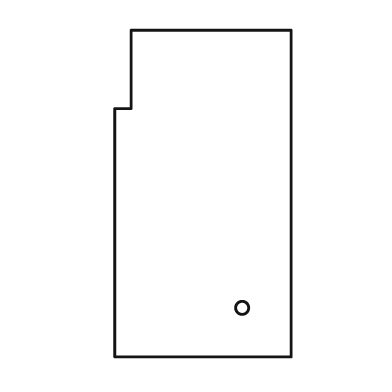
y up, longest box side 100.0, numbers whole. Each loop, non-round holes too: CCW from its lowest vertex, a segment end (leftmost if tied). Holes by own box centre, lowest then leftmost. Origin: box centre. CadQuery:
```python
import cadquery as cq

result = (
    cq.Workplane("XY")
    .moveTo(-27.0, -50.0)
    .lineTo(27.0, -50.0)
    .lineTo(27.0, 50.0)
    .lineTo(-22.0, 50.0)
    .lineTo(-22.0, 26.0)
    .lineTo(-27.0, 26.0)
    .close()
    .moveTo(12.0, -35.0)
    .circle(2.0)
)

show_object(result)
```